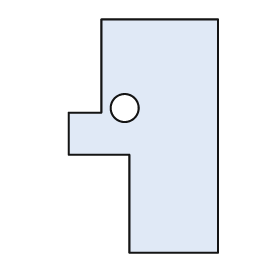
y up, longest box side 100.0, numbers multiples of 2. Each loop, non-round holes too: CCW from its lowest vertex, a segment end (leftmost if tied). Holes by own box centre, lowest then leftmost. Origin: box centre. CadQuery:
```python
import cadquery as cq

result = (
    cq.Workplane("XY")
    .moveTo(-6.0, -50.0)
    .lineTo(32.0, -50.0)
    .lineTo(32.0, 50.0)
    .lineTo(-18.0, 50.0)
    .lineTo(-18.0, 10.0)
    .lineTo(-32.0, 10.0)
    .lineTo(-32.0, -8.0)
    .lineTo(-6.0, -8.0)
    .close()
    .moveTo(-8.0, 12.0)
    .circle(6.0)
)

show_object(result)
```